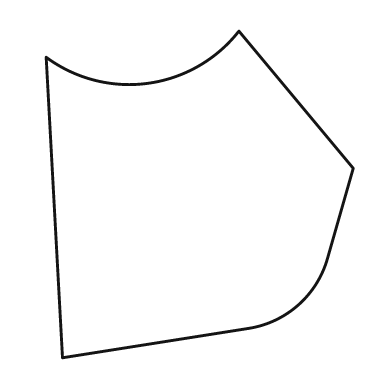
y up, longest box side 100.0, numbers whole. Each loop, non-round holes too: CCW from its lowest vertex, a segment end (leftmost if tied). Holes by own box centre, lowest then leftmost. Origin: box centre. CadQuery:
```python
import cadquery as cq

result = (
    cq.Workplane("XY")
    .moveTo(-42.0, -50.0)
    .lineTo(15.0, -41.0)
    .threePointArc((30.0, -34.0), (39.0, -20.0))
    .lineTo(47.0, 8.0)
    .lineTo(12.0, 50.0)
    .threePointArc((-16.0, 34.0), (-47.0, 42.0))
    .close()
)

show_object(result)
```